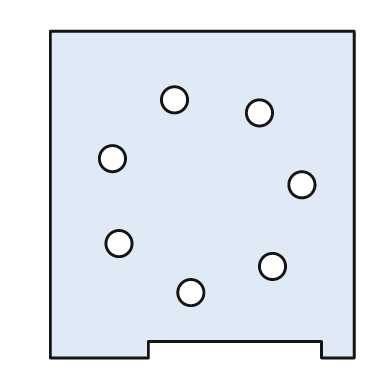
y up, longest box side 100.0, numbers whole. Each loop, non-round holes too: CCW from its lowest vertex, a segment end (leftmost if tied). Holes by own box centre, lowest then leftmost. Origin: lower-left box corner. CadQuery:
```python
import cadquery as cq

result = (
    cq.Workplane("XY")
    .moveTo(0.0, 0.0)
    .lineTo(30.0, 0.0)
    .lineTo(30.0, 5.0)
    .lineTo(83.0, 5.0)
    .lineTo(83.0, 0.0)
    .lineTo(93.0, 0.0)
    .lineTo(93.0, 100.0)
    .lineTo(0.0, 100.0)
    .close()
    .moveTo(43.0, 20.0)
    .circle(4.0)
    .moveTo(68.0, 28.0)
    .circle(4.0)
    .moveTo(21.0, 35.0)
    .circle(4.0)
    .moveTo(77.0, 53.0)
    .circle(4.0)
    .moveTo(19.0, 61.0)
    .circle(4.0)
    .moveTo(64.0, 75.0)
    .circle(4.0)
    .moveTo(38.0, 79.0)
    .circle(4.0)
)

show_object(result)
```